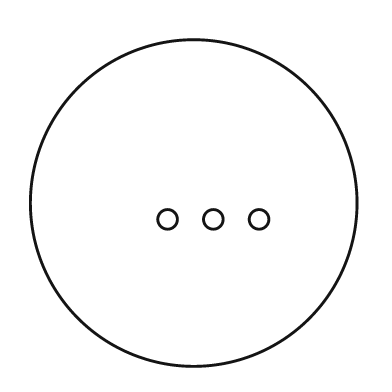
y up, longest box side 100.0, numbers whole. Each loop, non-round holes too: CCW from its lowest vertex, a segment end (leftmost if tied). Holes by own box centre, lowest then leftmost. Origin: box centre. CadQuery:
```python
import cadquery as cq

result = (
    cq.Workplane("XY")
    .moveTo(0.0, 0.0)
    .circle(50.0)
    .moveTo(-8.0, -5.0)
    .circle(3.0)
    .moveTo(6.0, -5.0)
    .circle(3.0)
    .moveTo(20.0, -5.0)
    .circle(3.0)
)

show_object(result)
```